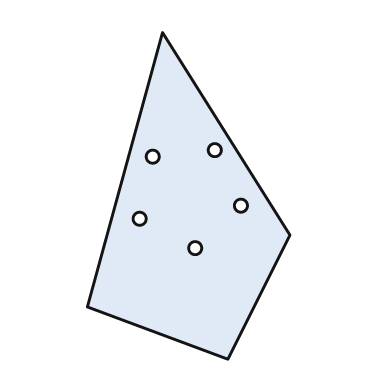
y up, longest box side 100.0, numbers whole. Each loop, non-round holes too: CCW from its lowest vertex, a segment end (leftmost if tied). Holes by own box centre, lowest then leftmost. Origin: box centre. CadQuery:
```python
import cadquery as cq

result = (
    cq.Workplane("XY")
    .moveTo(12.0, -50.0)
    .lineTo(31.0, -12.0)
    .lineTo(-8.0, 50.0)
    .lineTo(-31.0, -34.0)
    .close()
    .moveTo(2.0, -16.0)
    .circle(2.0)
    .moveTo(-15.0, -7.0)
    .circle(2.0)
    .moveTo(16.0, -3.0)
    .circle(2.0)
    .moveTo(-11.0, 12.0)
    .circle(2.0)
    .moveTo(8.0, 14.0)
    .circle(2.0)
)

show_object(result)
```